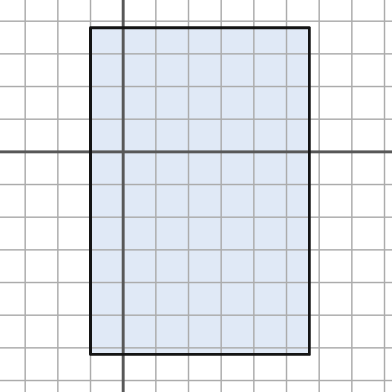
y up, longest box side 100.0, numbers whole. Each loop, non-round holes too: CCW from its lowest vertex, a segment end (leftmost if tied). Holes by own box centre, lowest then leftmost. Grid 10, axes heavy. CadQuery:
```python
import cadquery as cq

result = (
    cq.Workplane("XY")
    .moveTo(-10.0, -62.0)
    .lineTo(57.0, -62.0)
    .lineTo(57.0, 38.0)
    .lineTo(-10.0, 38.0)
    .close()
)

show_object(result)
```